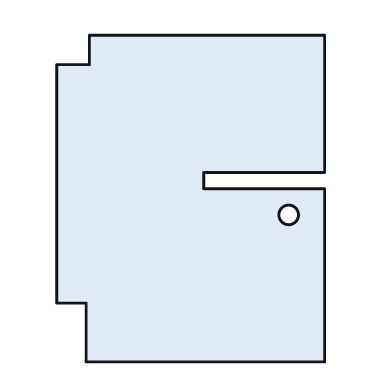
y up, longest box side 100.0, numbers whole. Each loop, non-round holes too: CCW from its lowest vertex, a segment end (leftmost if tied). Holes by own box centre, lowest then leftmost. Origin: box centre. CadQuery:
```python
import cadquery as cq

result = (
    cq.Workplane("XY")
    .moveTo(-32.0, -50.0)
    .lineTo(41.0, -50.0)
    .lineTo(41.0, 3.0)
    .lineTo(4.0, 3.0)
    .lineTo(4.0, 8.0)
    .lineTo(41.0, 8.0)
    .lineTo(41.0, 50.0)
    .lineTo(-31.0, 50.0)
    .lineTo(-31.0, 41.0)
    .lineTo(-41.0, 41.0)
    .lineTo(-41.0, -32.0)
    .lineTo(-32.0, -32.0)
    .close()
    .moveTo(30.0, -5.0)
    .circle(3.0)
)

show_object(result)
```